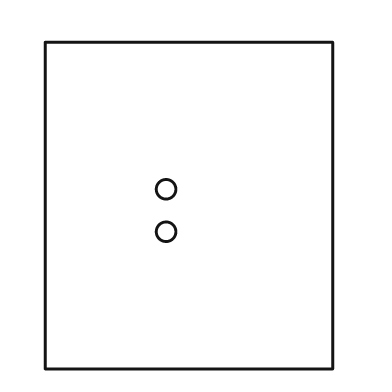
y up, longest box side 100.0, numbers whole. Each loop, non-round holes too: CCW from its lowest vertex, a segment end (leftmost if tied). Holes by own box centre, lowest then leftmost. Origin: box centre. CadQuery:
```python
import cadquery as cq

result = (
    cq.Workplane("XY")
    .moveTo(-44.0, -50.0)
    .lineTo(44.0, -50.0)
    .lineTo(44.0, 50.0)
    .lineTo(-44.0, 50.0)
    .close()
    .moveTo(-7.0, -8.0)
    .circle(3.0)
    .moveTo(-7.0, 5.0)
    .circle(3.0)
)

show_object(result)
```